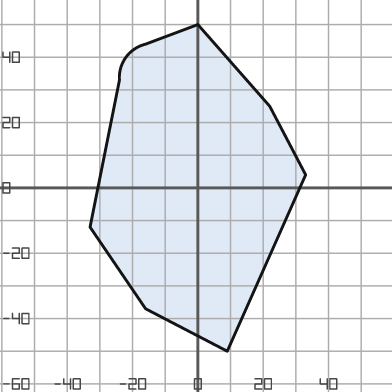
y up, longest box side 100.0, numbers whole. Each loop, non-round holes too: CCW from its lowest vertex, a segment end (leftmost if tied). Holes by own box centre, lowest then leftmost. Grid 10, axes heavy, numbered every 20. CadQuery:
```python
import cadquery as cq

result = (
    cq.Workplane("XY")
    .moveTo(9.0, -50.0)
    .lineTo(33.0, 4.0)
    .lineTo(22.0, 25.0)
    .lineTo(0.0, 50.0)
    .lineTo(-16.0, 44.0)
    .threePointArc((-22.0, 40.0), (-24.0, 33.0))
    .lineTo(-33.0, -12.0)
    .lineTo(-16.0, -37.0)
    .close()
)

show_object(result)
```